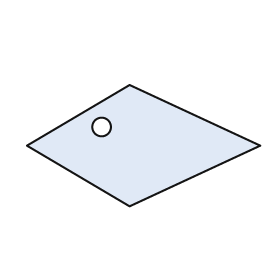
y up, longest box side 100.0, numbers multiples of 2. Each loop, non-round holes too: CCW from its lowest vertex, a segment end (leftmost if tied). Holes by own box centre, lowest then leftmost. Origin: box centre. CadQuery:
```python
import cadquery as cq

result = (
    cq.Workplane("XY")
    .moveTo(-6.0, -26.0)
    .lineTo(50.0, 0.0)
    .lineTo(-6.0, 26.0)
    .lineTo(-50.0, 0.0)
    .close()
    .moveTo(-18.0, 8.0)
    .circle(4.0)
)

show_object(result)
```